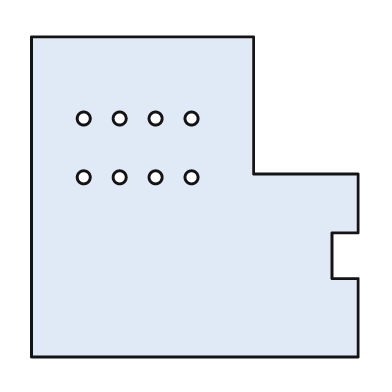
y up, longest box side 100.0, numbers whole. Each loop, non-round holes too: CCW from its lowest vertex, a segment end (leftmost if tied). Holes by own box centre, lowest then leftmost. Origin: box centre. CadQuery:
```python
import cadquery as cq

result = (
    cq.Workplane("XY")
    .moveTo(-50.0, -49.0)
    .lineTo(50.0, -49.0)
    .lineTo(50.0, -25.0)
    .lineTo(42.0, -25.0)
    .lineTo(42.0, -11.0)
    .lineTo(50.0, -11.0)
    .lineTo(50.0, 7.0)
    .lineTo(18.0, 7.0)
    .lineTo(18.0, 49.0)
    .lineTo(-50.0, 49.0)
    .close()
    .moveTo(-34.0, 6.0)
    .circle(2.0)
    .moveTo(-23.0, 6.0)
    .circle(2.0)
    .moveTo(-12.0, 6.0)
    .circle(2.0)
    .moveTo(-1.0, 6.0)
    .circle(2.0)
    .moveTo(-34.0, 24.0)
    .circle(2.0)
    .moveTo(-23.0, 24.0)
    .circle(2.0)
    .moveTo(-12.0, 24.0)
    .circle(2.0)
    .moveTo(-1.0, 24.0)
    .circle(2.0)
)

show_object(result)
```